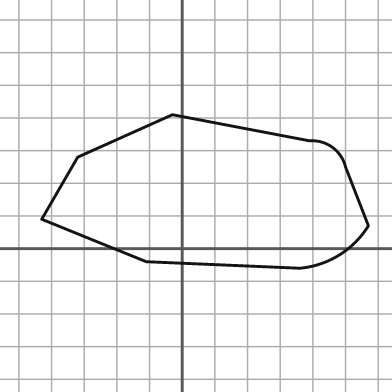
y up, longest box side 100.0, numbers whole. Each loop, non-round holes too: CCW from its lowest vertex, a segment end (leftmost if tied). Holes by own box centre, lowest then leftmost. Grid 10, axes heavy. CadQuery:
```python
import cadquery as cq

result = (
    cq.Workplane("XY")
    .moveTo(36.0, -6.0)
    .threePointArc((48.0, -2.0), (57.0, 7.0))
    .lineTo(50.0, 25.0)
    .threePointArc((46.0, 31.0), (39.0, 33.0))
    .lineTo(-3.0, 41.0)
    .lineTo(-32.0, 28.0)
    .lineTo(-43.0, 9.0)
    .lineTo(-11.0, -4.0)
    .close()
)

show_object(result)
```